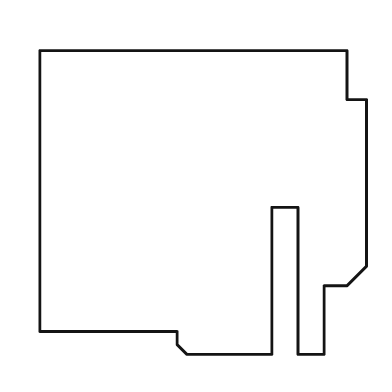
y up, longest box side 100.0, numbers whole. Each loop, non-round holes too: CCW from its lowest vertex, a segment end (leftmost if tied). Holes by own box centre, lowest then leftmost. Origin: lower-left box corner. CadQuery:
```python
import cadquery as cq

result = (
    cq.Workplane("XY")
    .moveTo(45.0, 0.0)
    .lineTo(71.0, 0.0)
    .lineTo(71.0, 45.0)
    .lineTo(79.0, 45.0)
    .lineTo(79.0, 0.0)
    .lineTo(87.0, 0.0)
    .lineTo(87.0, 21.0)
    .lineTo(94.0, 21.0)
    .lineTo(100.0, 27.0)
    .lineTo(100.0, 78.0)
    .lineTo(94.0, 78.0)
    .lineTo(94.0, 93.0)
    .lineTo(0.0, 93.0)
    .lineTo(0.0, 7.0)
    .lineTo(42.0, 7.0)
    .lineTo(42.0, 3.0)
    .close()
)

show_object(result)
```